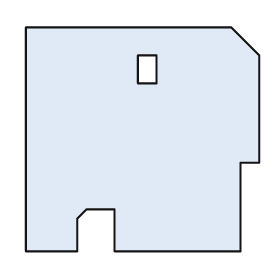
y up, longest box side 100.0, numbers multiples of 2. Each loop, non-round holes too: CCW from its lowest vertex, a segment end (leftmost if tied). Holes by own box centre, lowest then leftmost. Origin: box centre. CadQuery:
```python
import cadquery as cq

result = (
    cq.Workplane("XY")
    .moveTo(-50.0, -48.0)
    .lineTo(-28.0, -48.0)
    .lineTo(-28.0, -34.0)
    .lineTo(-24.0, -30.0)
    .lineTo(-12.0, -30.0)
    .lineTo(-12.0, -48.0)
    .lineTo(42.0, -48.0)
    .lineTo(42.0, -10.0)
    .lineTo(50.0, -10.0)
    .lineTo(50.0, 36.0)
    .lineTo(38.0, 48.0)
    .lineTo(-50.0, 48.0)
    .close()
    .moveTo(-2.0, 24.0)
    .lineTo(6.0, 24.0)
    .lineTo(6.0, 36.0)
    .lineTo(-2.0, 36.0)
    .close()
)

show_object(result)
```